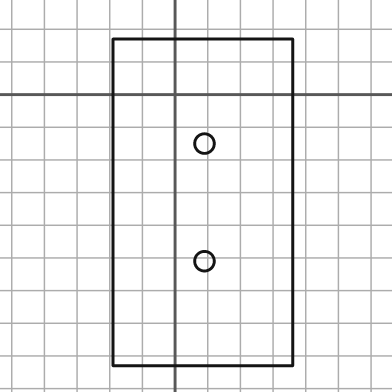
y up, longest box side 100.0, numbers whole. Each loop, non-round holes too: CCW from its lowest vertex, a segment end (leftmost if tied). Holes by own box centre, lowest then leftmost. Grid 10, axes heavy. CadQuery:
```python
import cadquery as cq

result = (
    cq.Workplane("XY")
    .moveTo(-19.0, -83.0)
    .lineTo(36.0, -83.0)
    .lineTo(36.0, 17.0)
    .lineTo(-19.0, 17.0)
    .close()
    .moveTo(9.0, -51.0)
    .circle(3.0)
    .moveTo(9.0, -15.0)
    .circle(3.0)
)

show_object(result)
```